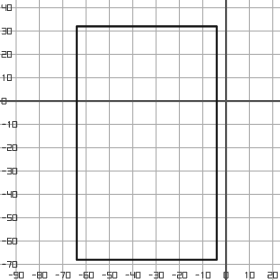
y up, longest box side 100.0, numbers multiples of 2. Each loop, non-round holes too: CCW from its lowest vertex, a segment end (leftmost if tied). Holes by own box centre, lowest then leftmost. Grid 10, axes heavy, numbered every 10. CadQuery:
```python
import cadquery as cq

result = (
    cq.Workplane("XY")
    .moveTo(-64.0, -68.0)
    .lineTo(-4.0, -68.0)
    .lineTo(-4.0, 32.0)
    .lineTo(-64.0, 32.0)
    .close()
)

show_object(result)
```